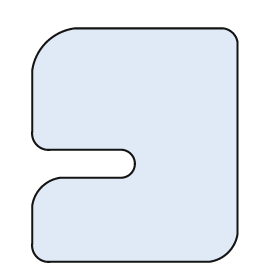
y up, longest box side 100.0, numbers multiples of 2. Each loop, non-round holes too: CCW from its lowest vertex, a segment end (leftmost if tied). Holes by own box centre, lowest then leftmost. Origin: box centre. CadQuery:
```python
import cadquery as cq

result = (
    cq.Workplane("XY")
    .moveTo(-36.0, -50.0)
    .lineTo(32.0, -50.0)
    .threePointArc((40.0, -46.0), (44.0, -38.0))
    .lineTo(44.0, 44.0)
    .threePointArc((42.0, 48.0), (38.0, 50.0))
    .lineTo(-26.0, 50.0)
    .threePointArc((-38.0, 44.0), (-44.0, 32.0))
    .lineTo(-44.0, 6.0)
    .threePointArc((-42.0, 0.0), (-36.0, -2.0))
    .lineTo(-6.0, -2.0)
    .threePointArc((0.0, -8.0), (-6.0, -14.0))
    .lineTo(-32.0, -14.0)
    .threePointArc((-40.0, -18.0), (-44.0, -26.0))
    .lineTo(-44.0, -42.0)
    .threePointArc((-42.0, -48.0), (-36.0, -50.0))
    .close()
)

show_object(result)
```